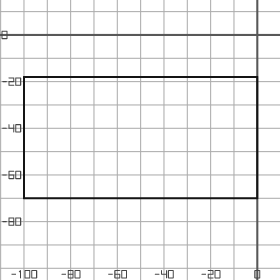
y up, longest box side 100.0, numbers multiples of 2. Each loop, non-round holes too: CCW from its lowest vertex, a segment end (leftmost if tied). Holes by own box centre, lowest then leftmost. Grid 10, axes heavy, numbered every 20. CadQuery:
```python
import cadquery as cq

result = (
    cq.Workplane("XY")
    .moveTo(-100.0, -70.0)
    .lineTo(0.0, -70.0)
    .lineTo(0.0, -18.0)
    .lineTo(-100.0, -18.0)
    .close()
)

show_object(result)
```